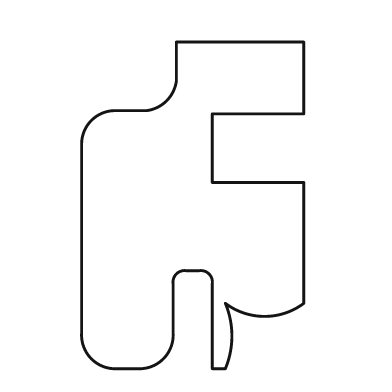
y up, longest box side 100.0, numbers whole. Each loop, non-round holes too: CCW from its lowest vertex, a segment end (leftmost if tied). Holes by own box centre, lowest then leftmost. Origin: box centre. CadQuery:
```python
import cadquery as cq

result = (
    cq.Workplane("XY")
    .moveTo(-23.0, -50.0)
    .lineTo(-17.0, -50.0)
    .threePointArc((-9.0, -47.0), (-6.0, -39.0))
    .lineTo(-6.0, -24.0)
    .threePointArc((-5.0, -21.0), (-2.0, -20.0))
    .lineTo(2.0, -20.0)
    .threePointArc((5.0, -21.0), (6.0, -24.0))
    .lineTo(6.0, -50.0)
    .lineTo(10.0, -50.0)
    .threePointArc((12.0, -40.0), (10.0, -30.0))
    .threePointArc((22.0, -34.0), (34.0, -30.0))
    .lineTo(34.0, 7.0)
    .lineTo(6.0, 7.0)
    .lineTo(6.0, 28.0)
    .lineTo(34.0, 28.0)
    .lineTo(34.0, 50.0)
    .lineTo(-5.0, 50.0)
    .lineTo(-5.0, 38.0)
    .threePointArc((-8.0, 32.0), (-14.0, 29.0))
    .lineTo(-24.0, 29.0)
    .threePointArc((-31.0, 26.0), (-34.0, 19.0))
    .lineTo(-34.0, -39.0)
    .threePointArc((-31.0, -47.0), (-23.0, -50.0))
    .close()
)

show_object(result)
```